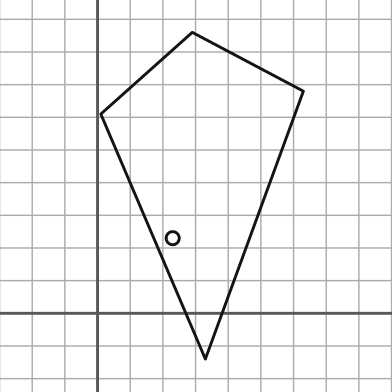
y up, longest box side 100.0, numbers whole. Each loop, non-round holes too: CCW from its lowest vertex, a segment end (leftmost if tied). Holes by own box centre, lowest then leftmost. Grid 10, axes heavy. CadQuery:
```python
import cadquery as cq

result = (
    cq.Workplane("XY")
    .moveTo(33.0, -14.0)
    .lineTo(63.0, 68.0)
    .lineTo(29.0, 86.0)
    .lineTo(1.0, 61.0)
    .close()
    .moveTo(23.0, 23.0)
    .circle(2.0)
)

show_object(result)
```